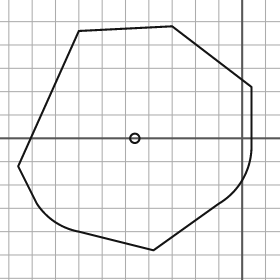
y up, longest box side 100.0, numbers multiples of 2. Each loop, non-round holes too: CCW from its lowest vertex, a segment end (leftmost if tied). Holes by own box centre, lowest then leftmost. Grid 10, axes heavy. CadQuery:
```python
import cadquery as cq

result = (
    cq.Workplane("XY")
    .moveTo(-38.0, -48.0)
    .lineTo(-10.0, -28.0)
    .threePointArc((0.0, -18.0), (4.0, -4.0))
    .lineTo(4.0, 22.0)
    .lineTo(-30.0, 48.0)
    .lineTo(-70.0, 46.0)
    .lineTo(-96.0, -12.0)
    .lineTo(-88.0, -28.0)
    .threePointArc((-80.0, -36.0), (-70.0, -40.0))
    .close()
    .moveTo(-46.0, 0.0)
    .circle(2.0)
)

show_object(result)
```